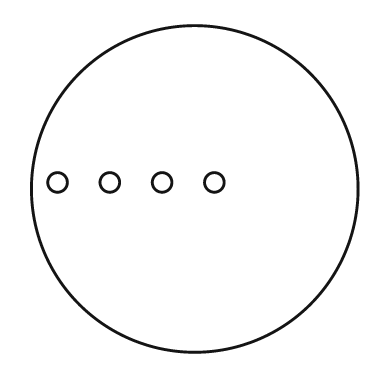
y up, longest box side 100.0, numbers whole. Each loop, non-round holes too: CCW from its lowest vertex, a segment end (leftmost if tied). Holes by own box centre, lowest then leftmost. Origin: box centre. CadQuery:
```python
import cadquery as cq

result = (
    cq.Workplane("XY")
    .moveTo(0.0, 0.0)
    .circle(50.0)
    .moveTo(-42.0, 2.0)
    .circle(3.0)
    .moveTo(-26.0, 2.0)
    .circle(3.0)
    .moveTo(-10.0, 2.0)
    .circle(3.0)
    .moveTo(6.0, 2.0)
    .circle(3.0)
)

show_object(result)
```